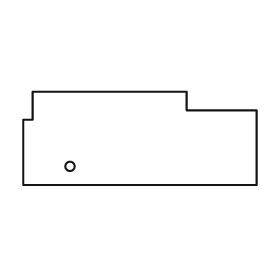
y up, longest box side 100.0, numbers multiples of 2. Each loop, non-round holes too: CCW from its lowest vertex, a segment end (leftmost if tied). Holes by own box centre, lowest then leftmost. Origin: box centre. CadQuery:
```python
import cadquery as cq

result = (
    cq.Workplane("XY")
    .moveTo(-50.0, -20.0)
    .lineTo(50.0, -20.0)
    .lineTo(50.0, 12.0)
    .lineTo(20.0, 12.0)
    .lineTo(20.0, 20.0)
    .lineTo(-46.0, 20.0)
    .lineTo(-46.0, 8.0)
    .lineTo(-50.0, 8.0)
    .close()
    .moveTo(-30.0, -12.0)
    .circle(2.0)
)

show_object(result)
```